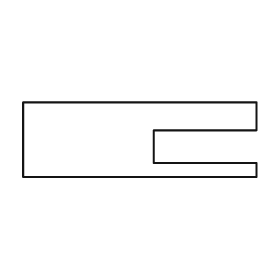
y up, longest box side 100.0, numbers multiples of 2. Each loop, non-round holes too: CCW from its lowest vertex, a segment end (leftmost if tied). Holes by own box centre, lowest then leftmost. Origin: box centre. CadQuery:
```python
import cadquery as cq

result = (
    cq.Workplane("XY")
    .moveTo(-50.0, -16.0)
    .lineTo(50.0, -16.0)
    .lineTo(50.0, -10.0)
    .lineTo(6.0, -10.0)
    .lineTo(6.0, 4.0)
    .lineTo(50.0, 4.0)
    .lineTo(50.0, 16.0)
    .lineTo(-50.0, 16.0)
    .close()
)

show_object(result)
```